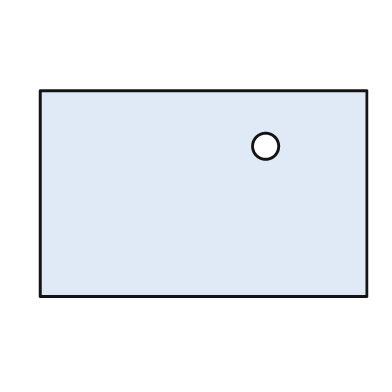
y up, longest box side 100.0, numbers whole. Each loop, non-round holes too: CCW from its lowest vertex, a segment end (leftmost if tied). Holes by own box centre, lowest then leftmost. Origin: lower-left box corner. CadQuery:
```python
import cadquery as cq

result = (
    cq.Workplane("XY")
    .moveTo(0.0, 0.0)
    .lineTo(100.0, 0.0)
    .lineTo(100.0, 63.0)
    .lineTo(0.0, 63.0)
    .close()
    .moveTo(69.0, 46.0)
    .circle(4.0)
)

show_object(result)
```